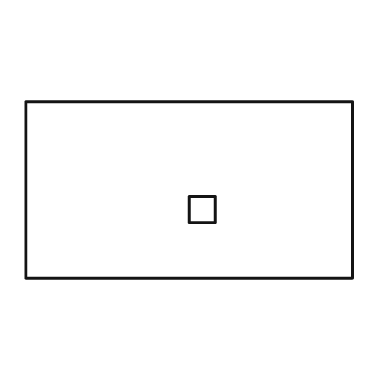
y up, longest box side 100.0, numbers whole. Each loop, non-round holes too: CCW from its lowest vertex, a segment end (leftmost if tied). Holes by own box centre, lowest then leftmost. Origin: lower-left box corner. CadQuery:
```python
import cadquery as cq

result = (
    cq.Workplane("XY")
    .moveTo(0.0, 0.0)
    .lineTo(100.0, 0.0)
    .lineTo(100.0, 54.0)
    .lineTo(0.0, 54.0)
    .close()
    .moveTo(50.0, 17.0)
    .lineTo(58.0, 17.0)
    .lineTo(58.0, 25.0)
    .lineTo(50.0, 25.0)
    .close()
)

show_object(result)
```